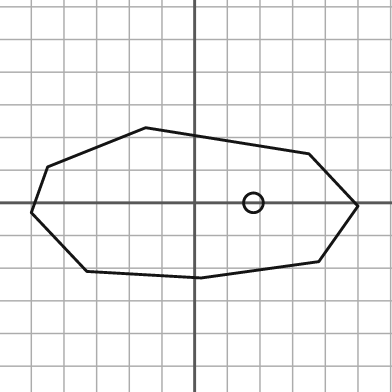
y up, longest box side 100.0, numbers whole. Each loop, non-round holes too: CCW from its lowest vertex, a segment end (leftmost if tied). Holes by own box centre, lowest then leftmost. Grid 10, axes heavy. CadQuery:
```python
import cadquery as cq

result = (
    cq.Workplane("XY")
    .moveTo(2.0, -23.0)
    .lineTo(38.0, -18.0)
    .lineTo(50.0, -1.0)
    .lineTo(35.0, 15.0)
    .lineTo(-15.0, 23.0)
    .lineTo(-45.0, 11.0)
    .lineTo(-50.0, -3.0)
    .lineTo(-33.0, -21.0)
    .close()
    .moveTo(18.0, 0.0)
    .circle(3.0)
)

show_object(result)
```